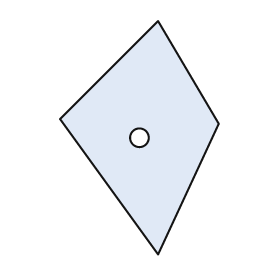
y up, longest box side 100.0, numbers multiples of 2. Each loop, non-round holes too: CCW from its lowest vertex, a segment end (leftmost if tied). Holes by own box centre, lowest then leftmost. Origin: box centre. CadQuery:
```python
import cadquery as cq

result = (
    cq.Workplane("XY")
    .moveTo(8.0, -50.0)
    .lineTo(34.0, 6.0)
    .lineTo(8.0, 50.0)
    .lineTo(-34.0, 8.0)
    .close()
    .moveTo(0.0, 0.0)
    .circle(4.0)
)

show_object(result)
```